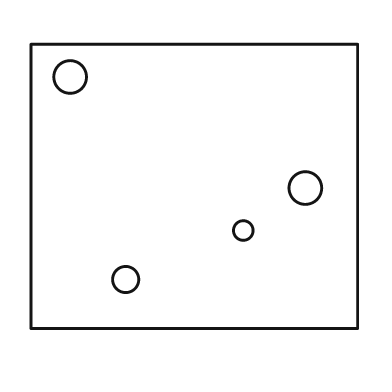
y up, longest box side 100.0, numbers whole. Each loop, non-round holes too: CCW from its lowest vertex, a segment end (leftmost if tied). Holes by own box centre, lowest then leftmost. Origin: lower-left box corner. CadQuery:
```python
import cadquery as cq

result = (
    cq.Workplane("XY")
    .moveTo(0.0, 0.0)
    .lineTo(100.0, 0.0)
    .lineTo(100.0, 87.0)
    .lineTo(0.0, 87.0)
    .close()
    .moveTo(29.0, 15.0)
    .circle(4.0)
    .moveTo(65.0, 30.0)
    .circle(3.0)
    .moveTo(84.0, 43.0)
    .circle(5.0)
    .moveTo(12.0, 77.0)
    .circle(5.0)
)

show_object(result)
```